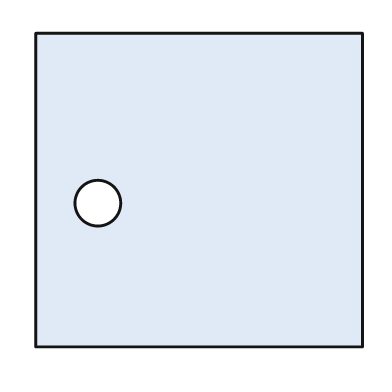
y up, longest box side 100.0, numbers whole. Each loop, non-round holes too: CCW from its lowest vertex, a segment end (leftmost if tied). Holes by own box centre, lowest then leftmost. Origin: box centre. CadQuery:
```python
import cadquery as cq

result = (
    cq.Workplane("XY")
    .moveTo(-50.0, -48.0)
    .lineTo(50.0, -48.0)
    .lineTo(50.0, 48.0)
    .lineTo(-50.0, 48.0)
    .close()
    .moveTo(-31.0, -4.0)
    .circle(7.0)
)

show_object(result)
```